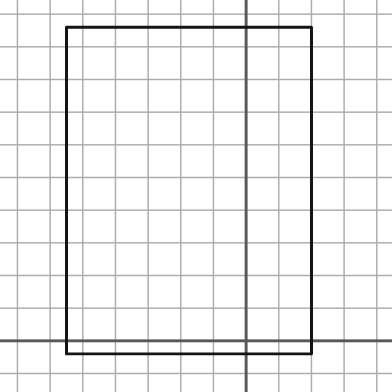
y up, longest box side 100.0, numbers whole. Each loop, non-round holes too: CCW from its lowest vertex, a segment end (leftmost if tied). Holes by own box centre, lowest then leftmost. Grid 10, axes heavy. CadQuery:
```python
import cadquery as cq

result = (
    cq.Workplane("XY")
    .moveTo(-55.0, -4.0)
    .lineTo(20.0, -4.0)
    .lineTo(20.0, 96.0)
    .lineTo(-55.0, 96.0)
    .close()
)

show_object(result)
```